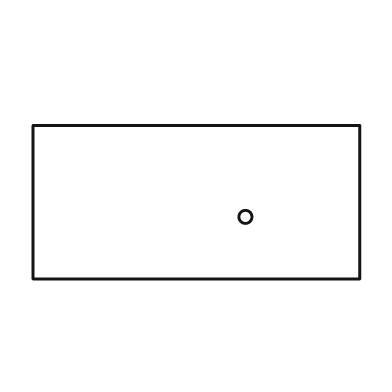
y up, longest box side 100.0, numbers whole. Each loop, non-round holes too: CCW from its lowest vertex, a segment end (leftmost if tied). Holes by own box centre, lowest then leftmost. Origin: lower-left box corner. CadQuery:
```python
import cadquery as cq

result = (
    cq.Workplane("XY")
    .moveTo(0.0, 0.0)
    .lineTo(100.0, 0.0)
    .lineTo(100.0, 47.0)
    .lineTo(0.0, 47.0)
    .close()
    .moveTo(65.0, 19.0)
    .circle(2.0)
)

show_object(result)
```